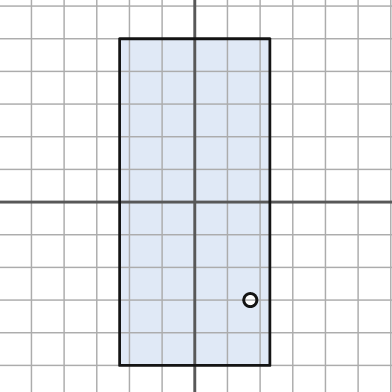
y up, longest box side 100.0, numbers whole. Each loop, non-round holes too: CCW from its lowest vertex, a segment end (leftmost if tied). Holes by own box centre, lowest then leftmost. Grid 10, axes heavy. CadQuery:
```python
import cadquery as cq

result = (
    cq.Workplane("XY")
    .moveTo(-23.0, -50.0)
    .lineTo(23.0, -50.0)
    .lineTo(23.0, 50.0)
    .lineTo(-23.0, 50.0)
    .close()
    .moveTo(17.0, -30.0)
    .circle(2.0)
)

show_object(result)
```